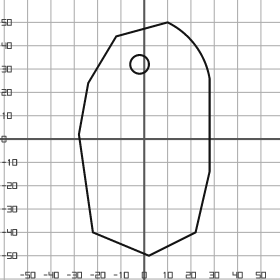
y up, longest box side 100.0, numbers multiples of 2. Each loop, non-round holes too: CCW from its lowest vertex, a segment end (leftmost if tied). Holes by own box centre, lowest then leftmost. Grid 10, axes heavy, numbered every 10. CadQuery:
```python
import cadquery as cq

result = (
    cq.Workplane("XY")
    .moveTo(2.0, -50.0)
    .lineTo(22.0, -40.0)
    .lineTo(28.0, -14.0)
    .lineTo(28.0, 26.0)
    .threePointArc((22.0, 40.0), (10.0, 50.0))
    .lineTo(-12.0, 44.0)
    .lineTo(-24.0, 24.0)
    .lineTo(-28.0, 2.0)
    .lineTo(-22.0, -40.0)
    .close()
    .moveTo(-2.0, 32.0)
    .circle(4.0)
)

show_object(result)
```